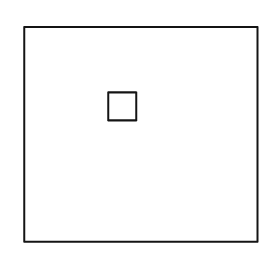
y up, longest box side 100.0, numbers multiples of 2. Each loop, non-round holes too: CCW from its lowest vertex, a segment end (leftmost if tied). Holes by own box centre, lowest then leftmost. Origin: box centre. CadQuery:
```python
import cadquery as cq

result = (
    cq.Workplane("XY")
    .moveTo(-50.0, -46.0)
    .lineTo(50.0, -46.0)
    .lineTo(50.0, 46.0)
    .lineTo(-50.0, 46.0)
    .close()
    .moveTo(-14.0, 6.0)
    .lineTo(-2.0, 6.0)
    .lineTo(-2.0, 18.0)
    .lineTo(-14.0, 18.0)
    .close()
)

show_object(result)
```